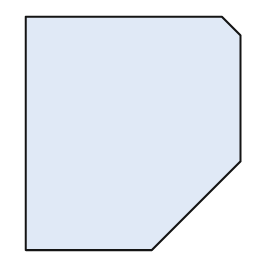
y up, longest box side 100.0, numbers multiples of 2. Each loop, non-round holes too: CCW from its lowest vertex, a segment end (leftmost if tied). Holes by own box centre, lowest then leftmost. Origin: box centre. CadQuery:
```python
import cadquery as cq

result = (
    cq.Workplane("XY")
    .moveTo(-46.0, -50.0)
    .lineTo(8.0, -50.0)
    .lineTo(46.0, -12.0)
    .lineTo(46.0, 42.0)
    .lineTo(38.0, 50.0)
    .lineTo(-46.0, 50.0)
    .close()
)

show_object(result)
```